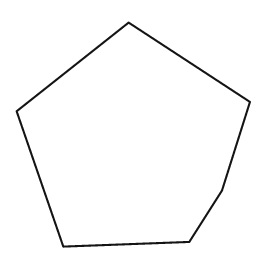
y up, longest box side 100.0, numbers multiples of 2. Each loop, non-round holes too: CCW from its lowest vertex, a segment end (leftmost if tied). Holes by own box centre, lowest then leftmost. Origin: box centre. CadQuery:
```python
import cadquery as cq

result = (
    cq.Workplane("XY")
    .moveTo(-30.0, -48.0)
    .lineTo(24.0, -46.0)
    .lineTo(38.0, -24.0)
    .lineTo(50.0, 14.0)
    .lineTo(-2.0, 48.0)
    .lineTo(-50.0, 10.0)
    .close()
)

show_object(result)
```